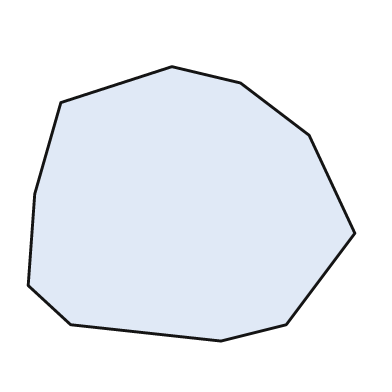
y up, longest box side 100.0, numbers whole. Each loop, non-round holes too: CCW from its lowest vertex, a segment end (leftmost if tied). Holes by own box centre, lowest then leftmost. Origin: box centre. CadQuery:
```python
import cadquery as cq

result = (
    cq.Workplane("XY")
    .moveTo(9.0, -42.0)
    .lineTo(29.0, -37.0)
    .lineTo(50.0, -9.0)
    .lineTo(36.0, 21.0)
    .lineTo(15.0, 37.0)
    .lineTo(-6.0, 42.0)
    .lineTo(-40.0, 31.0)
    .lineTo(-48.0, 3.0)
    .lineTo(-50.0, -25.0)
    .lineTo(-37.0, -37.0)
    .close()
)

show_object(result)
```